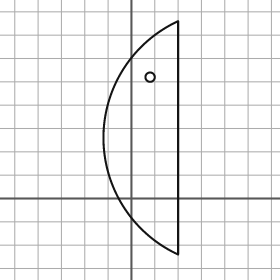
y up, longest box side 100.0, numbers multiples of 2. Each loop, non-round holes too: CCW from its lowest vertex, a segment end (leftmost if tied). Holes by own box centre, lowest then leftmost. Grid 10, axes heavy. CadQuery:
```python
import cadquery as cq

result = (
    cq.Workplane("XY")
    .moveTo(20.0, -24.0)
    .lineTo(20.0, 76.0)
    .threePointArc((-12.0, 26.0), (20.0, -24.0))
    .close()
    .moveTo(8.0, 52.0)
    .circle(2.0)
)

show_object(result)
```